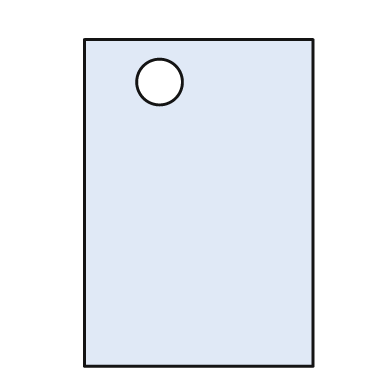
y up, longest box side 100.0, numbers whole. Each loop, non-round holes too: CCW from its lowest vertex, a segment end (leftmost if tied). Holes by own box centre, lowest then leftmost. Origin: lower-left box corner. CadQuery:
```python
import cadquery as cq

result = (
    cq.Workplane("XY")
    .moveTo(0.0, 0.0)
    .lineTo(70.0, 0.0)
    .lineTo(70.0, 100.0)
    .lineTo(0.0, 100.0)
    .close()
    .moveTo(23.0, 87.0)
    .circle(7.0)
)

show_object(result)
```